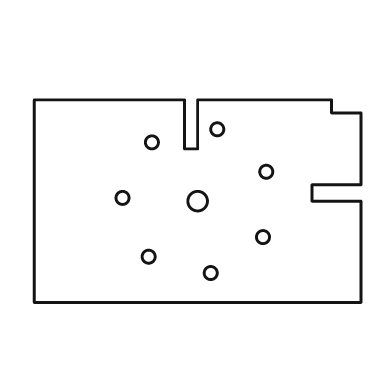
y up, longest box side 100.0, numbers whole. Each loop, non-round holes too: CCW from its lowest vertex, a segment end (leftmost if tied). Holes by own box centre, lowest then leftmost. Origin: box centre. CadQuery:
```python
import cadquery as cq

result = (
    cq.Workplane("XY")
    .moveTo(-50.0, -31.0)
    .lineTo(50.0, -31.0)
    .lineTo(50.0, 0.0)
    .lineTo(35.0, 0.0)
    .lineTo(35.0, 5.0)
    .lineTo(50.0, 5.0)
    .lineTo(50.0, 27.0)
    .lineTo(41.0, 27.0)
    .lineTo(41.0, 31.0)
    .lineTo(0.0, 31.0)
    .lineTo(0.0, 16.0)
    .lineTo(-4.0, 16.0)
    .lineTo(-4.0, 31.0)
    .lineTo(-50.0, 31.0)
    .close()
    .moveTo(4.0, -22.0)
    .circle(2.0)
    .moveTo(-15.0, -17.0)
    .circle(2.0)
    .moveTo(20.0, -11.0)
    .circle(2.0)
    .moveTo(0.0, 0.0)
    .circle(3.0)
    .moveTo(-23.0, 1.0)
    .circle(2.0)
    .moveTo(21.0, 9.0)
    .circle(2.0)
    .moveTo(-14.0, 18.0)
    .circle(2.0)
    .moveTo(6.0, 22.0)
    .circle(2.0)
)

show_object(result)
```